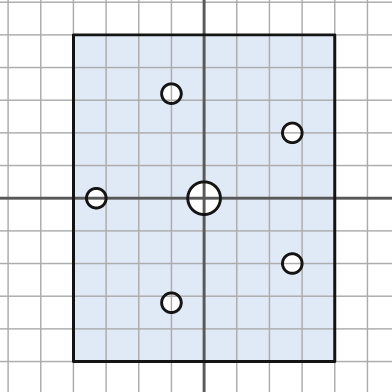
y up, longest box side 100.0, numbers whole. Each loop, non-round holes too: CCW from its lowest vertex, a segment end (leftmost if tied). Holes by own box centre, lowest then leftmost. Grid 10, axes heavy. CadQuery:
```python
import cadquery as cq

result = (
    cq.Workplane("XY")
    .moveTo(-40.0, -50.0)
    .lineTo(40.0, -50.0)
    .lineTo(40.0, 50.0)
    .lineTo(-40.0, 50.0)
    .close()
    .moveTo(-10.0, -32.0)
    .circle(3.0)
    .moveTo(27.0, -20.0)
    .circle(3.0)
    .moveTo(-33.0, 0.0)
    .circle(3.0)
    .moveTo(0.0, 0.0)
    .circle(5.0)
    .moveTo(27.0, 20.0)
    .circle(3.0)
    .moveTo(-10.0, 32.0)
    .circle(3.0)
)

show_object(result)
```